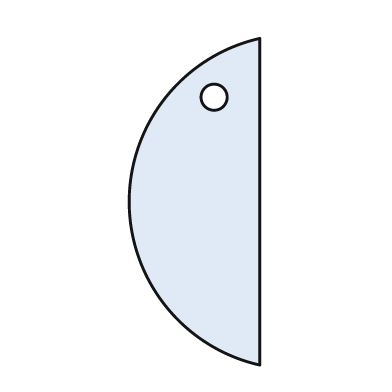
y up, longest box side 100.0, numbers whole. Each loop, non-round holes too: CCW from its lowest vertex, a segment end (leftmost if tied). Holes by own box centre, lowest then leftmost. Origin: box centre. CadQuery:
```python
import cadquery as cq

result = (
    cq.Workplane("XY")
    .moveTo(20.0, -50.0)
    .lineTo(20.0, 50.0)
    .threePointArc((-20.0, 0.0), (20.0, -50.0))
    .close()
    .moveTo(6.0, 32.0)
    .circle(4.0)
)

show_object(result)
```